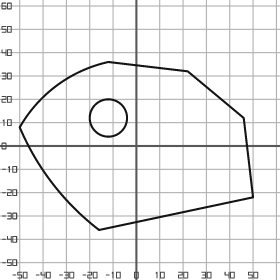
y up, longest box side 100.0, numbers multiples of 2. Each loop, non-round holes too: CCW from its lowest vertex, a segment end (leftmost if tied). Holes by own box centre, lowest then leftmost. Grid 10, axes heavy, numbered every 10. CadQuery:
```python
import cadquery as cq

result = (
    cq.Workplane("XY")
    .moveTo(-16.0, -36.0)
    .lineTo(50.0, -22.0)
    .lineTo(46.0, 12.0)
    .lineTo(22.0, 32.0)
    .lineTo(-12.0, 36.0)
    .threePointArc((-34.0, 26.0), (-50.0, 8.0))
    .threePointArc((-36.0, -16.0), (-16.0, -36.0))
    .close()
    .moveTo(-12.0, 12.0)
    .circle(8.0)
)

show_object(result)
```